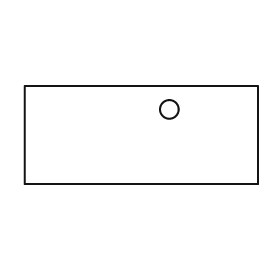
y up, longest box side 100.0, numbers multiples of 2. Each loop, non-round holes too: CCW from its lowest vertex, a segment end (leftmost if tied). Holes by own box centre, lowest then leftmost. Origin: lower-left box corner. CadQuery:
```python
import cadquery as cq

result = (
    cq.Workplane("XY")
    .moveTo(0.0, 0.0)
    .lineTo(100.0, 0.0)
    .lineTo(100.0, 42.0)
    .lineTo(0.0, 42.0)
    .close()
    .moveTo(62.0, 32.0)
    .circle(4.0)
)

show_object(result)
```